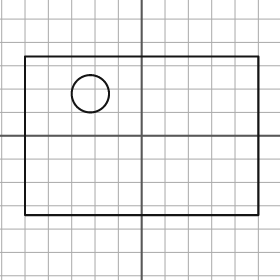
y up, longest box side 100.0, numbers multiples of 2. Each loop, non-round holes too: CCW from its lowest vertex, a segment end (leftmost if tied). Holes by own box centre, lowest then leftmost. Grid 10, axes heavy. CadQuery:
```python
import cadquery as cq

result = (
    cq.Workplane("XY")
    .moveTo(-50.0, -34.0)
    .lineTo(50.0, -34.0)
    .lineTo(50.0, 34.0)
    .lineTo(-50.0, 34.0)
    .close()
    .moveTo(-22.0, 18.0)
    .circle(8.0)
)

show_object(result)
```